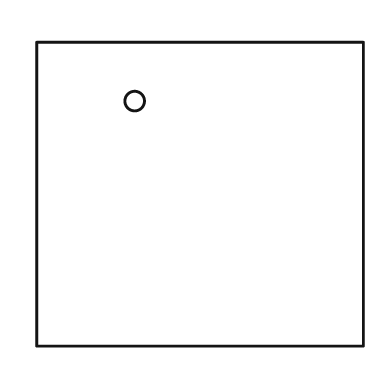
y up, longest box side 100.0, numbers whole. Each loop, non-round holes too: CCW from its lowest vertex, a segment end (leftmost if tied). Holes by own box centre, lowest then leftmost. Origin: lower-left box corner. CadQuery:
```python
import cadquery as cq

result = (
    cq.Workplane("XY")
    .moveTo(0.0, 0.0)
    .lineTo(100.0, 0.0)
    .lineTo(100.0, 93.0)
    .lineTo(0.0, 93.0)
    .close()
    .moveTo(30.0, 75.0)
    .circle(3.0)
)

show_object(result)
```